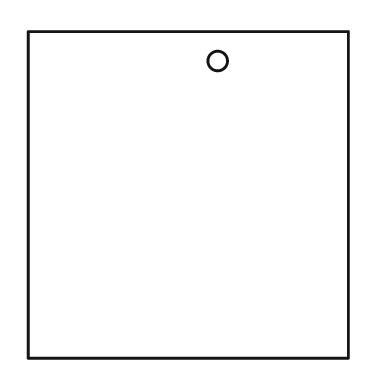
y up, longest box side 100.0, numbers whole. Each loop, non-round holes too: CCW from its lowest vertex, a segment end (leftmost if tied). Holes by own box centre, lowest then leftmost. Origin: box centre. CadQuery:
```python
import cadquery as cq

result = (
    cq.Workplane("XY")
    .moveTo(-49.0, -50.0)
    .lineTo(49.0, -50.0)
    .lineTo(49.0, 50.0)
    .lineTo(-49.0, 50.0)
    .close()
    .moveTo(9.0, 41.0)
    .circle(3.0)
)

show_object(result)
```